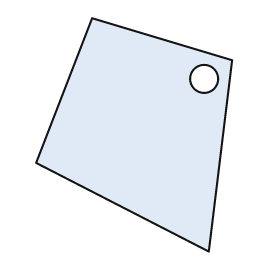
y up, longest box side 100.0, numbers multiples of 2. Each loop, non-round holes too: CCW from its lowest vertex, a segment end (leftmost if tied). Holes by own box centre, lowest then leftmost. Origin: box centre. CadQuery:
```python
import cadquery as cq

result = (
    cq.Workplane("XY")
    .moveTo(32.0, -50.0)
    .lineTo(42.0, 32.0)
    .lineTo(-18.0, 50.0)
    .lineTo(-42.0, -12.0)
    .close()
    .moveTo(30.0, 24.0)
    .circle(6.0)
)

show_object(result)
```